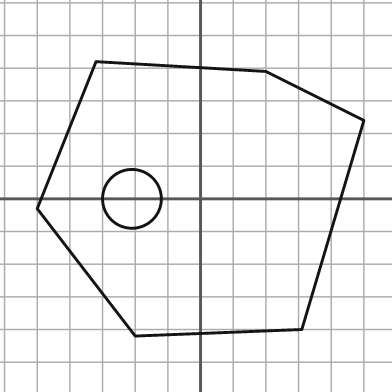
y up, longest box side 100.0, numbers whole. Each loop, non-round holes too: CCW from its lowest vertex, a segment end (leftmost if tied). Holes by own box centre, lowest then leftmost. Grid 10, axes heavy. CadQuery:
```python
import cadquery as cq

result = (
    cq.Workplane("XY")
    .moveTo(-20.0, -42.0)
    .lineTo(31.0, -40.0)
    .lineTo(50.0, 24.0)
    .lineTo(20.0, 39.0)
    .lineTo(-32.0, 42.0)
    .lineTo(-50.0, -3.0)
    .close()
    .moveTo(-21.0, 0.0)
    .circle(9.0)
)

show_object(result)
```